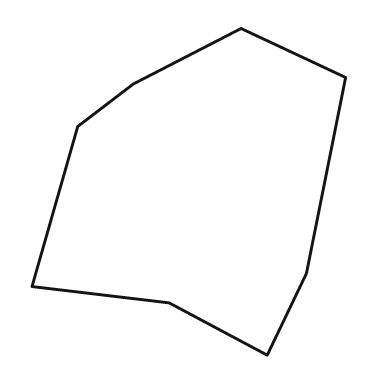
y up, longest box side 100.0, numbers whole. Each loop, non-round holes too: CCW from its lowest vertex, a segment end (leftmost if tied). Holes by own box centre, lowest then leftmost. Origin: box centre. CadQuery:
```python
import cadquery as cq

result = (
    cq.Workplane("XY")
    .moveTo(24.0, -50.0)
    .lineTo(36.0, -25.0)
    .lineTo(48.0, 35.0)
    .lineTo(16.0, 50.0)
    .lineTo(-17.0, 33.0)
    .lineTo(-34.0, 20.0)
    .lineTo(-48.0, -29.0)
    .lineTo(-6.0, -34.0)
    .close()
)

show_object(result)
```